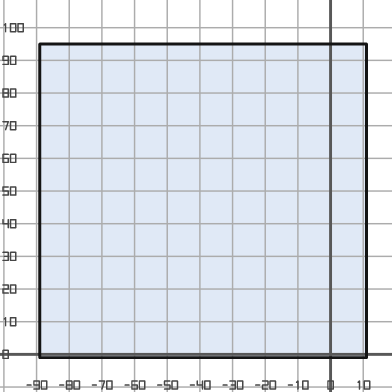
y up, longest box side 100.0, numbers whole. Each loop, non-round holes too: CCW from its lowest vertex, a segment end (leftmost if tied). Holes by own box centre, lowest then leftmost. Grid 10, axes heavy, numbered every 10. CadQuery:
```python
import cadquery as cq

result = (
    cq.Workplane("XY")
    .moveTo(-89.0, -1.0)
    .lineTo(11.0, -1.0)
    .lineTo(11.0, 95.0)
    .lineTo(-89.0, 95.0)
    .close()
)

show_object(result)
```